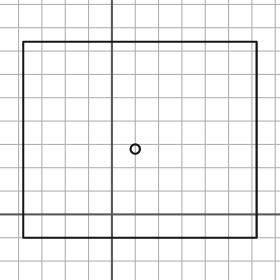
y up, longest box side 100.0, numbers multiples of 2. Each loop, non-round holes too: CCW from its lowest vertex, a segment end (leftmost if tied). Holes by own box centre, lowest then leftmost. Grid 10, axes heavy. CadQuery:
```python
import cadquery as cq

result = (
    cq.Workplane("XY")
    .moveTo(-38.0, -10.0)
    .lineTo(62.0, -10.0)
    .lineTo(62.0, 74.0)
    .lineTo(-38.0, 74.0)
    .close()
    .moveTo(10.0, 28.0)
    .circle(2.0)
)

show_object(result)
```